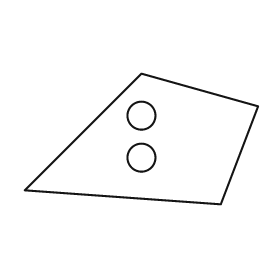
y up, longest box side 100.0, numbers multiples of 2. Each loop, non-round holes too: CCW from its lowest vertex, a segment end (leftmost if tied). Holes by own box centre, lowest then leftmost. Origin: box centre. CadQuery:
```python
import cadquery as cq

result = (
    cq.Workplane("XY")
    .moveTo(34.0, -28.0)
    .lineTo(50.0, 14.0)
    .lineTo(0.0, 28.0)
    .lineTo(-50.0, -22.0)
    .close()
    .moveTo(0.0, -8.0)
    .circle(6.0)
    .moveTo(0.0, 10.0)
    .circle(6.0)
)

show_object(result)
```